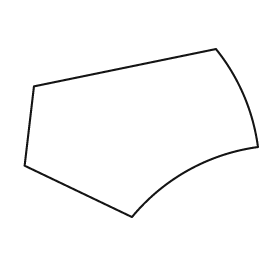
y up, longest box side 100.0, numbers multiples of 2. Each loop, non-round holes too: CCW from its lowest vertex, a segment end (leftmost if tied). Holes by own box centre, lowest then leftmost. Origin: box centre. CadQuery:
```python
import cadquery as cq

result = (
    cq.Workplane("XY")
    .moveTo(-4.0, -36.0)
    .threePointArc((20.0, -16.0), (50.0, -6.0))
    .threePointArc((44.0, 16.0), (32.0, 36.0))
    .lineTo(-46.0, 20.0)
    .lineTo(-50.0, -14.0)
    .close()
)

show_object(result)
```